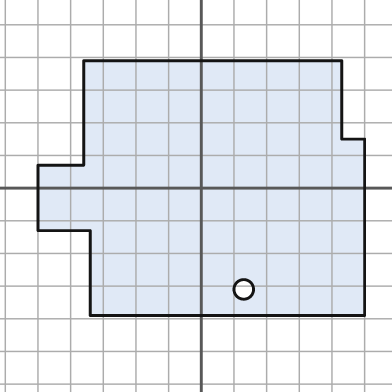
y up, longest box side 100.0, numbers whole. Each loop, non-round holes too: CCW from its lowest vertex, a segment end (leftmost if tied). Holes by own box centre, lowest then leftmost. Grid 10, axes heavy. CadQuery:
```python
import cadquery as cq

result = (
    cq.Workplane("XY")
    .moveTo(-34.0, -39.0)
    .lineTo(50.0, -39.0)
    .lineTo(50.0, 15.0)
    .lineTo(43.0, 15.0)
    .lineTo(43.0, 39.0)
    .lineTo(-36.0, 39.0)
    .lineTo(-36.0, 7.0)
    .lineTo(-50.0, 7.0)
    .lineTo(-50.0, -13.0)
    .lineTo(-34.0, -13.0)
    .close()
    .moveTo(13.0, -31.0)
    .circle(3.0)
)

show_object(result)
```